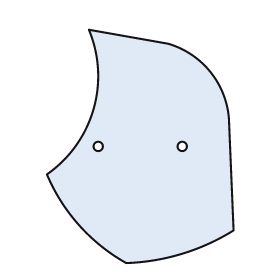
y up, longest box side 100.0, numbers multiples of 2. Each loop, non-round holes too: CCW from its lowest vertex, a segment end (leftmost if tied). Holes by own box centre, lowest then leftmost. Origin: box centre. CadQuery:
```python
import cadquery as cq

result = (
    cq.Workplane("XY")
    .moveTo(-6.0, -50.0)
    .threePointArc((18.0, -46.0), (40.0, -36.0))
    .lineTo(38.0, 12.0)
    .threePointArc((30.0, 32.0), (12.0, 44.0))
    .lineTo(-22.0, 50.0)
    .threePointArc((-20.0, 16.0), (-40.0, -12.0))
    .threePointArc((-26.0, -34.0), (-6.0, -50.0))
    .close()
    .moveTo(-18.0, 0.0)
    .circle(2.0)
    .moveTo(18.0, 0.0)
    .circle(2.0)
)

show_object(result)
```